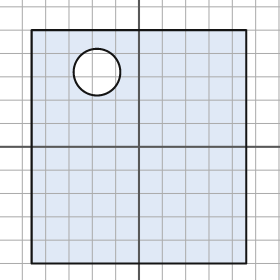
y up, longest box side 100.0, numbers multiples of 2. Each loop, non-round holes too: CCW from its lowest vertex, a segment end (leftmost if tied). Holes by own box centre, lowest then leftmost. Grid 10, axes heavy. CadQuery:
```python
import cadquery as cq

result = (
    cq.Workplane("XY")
    .moveTo(-46.0, -50.0)
    .lineTo(46.0, -50.0)
    .lineTo(46.0, 50.0)
    .lineTo(-46.0, 50.0)
    .close()
    .moveTo(-18.0, 32.0)
    .circle(10.0)
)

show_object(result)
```